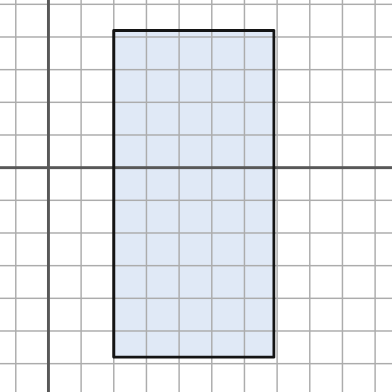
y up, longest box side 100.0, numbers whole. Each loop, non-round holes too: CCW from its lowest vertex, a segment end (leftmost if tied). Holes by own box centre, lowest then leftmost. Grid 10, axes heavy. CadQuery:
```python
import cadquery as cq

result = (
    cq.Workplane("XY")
    .moveTo(20.0, -58.0)
    .lineTo(69.0, -58.0)
    .lineTo(69.0, 42.0)
    .lineTo(20.0, 42.0)
    .close()
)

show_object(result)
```